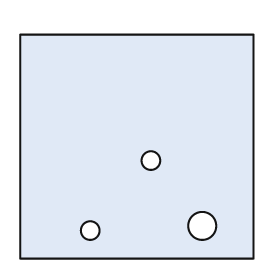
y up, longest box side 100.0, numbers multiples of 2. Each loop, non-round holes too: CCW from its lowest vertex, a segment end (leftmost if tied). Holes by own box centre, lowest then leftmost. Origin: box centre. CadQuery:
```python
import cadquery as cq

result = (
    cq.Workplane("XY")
    .moveTo(-50.0, -48.0)
    .lineTo(50.0, -48.0)
    .lineTo(50.0, 48.0)
    .lineTo(-50.0, 48.0)
    .close()
    .moveTo(-20.0, -36.0)
    .circle(4.0)
    .moveTo(28.0, -34.0)
    .circle(6.0)
    .moveTo(6.0, -6.0)
    .circle(4.0)
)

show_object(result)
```